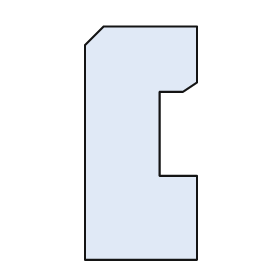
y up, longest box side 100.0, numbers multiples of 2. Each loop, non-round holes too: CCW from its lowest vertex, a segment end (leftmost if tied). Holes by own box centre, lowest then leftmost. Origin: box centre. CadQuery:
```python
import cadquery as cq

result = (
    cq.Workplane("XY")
    .moveTo(-24.0, -50.0)
    .lineTo(24.0, -50.0)
    .lineTo(24.0, -14.0)
    .lineTo(8.0, -14.0)
    .lineTo(8.0, 22.0)
    .lineTo(18.0, 22.0)
    .lineTo(24.0, 26.0)
    .lineTo(24.0, 50.0)
    .lineTo(-16.0, 50.0)
    .lineTo(-24.0, 42.0)
    .close()
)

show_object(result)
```